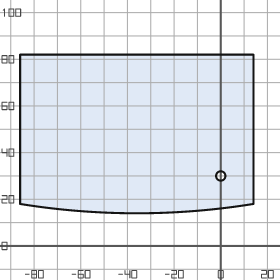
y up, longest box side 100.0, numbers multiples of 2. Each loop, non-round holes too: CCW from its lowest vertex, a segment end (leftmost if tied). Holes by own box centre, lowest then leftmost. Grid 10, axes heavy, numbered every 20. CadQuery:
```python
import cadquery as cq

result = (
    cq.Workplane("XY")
    .moveTo(-86.0, 18.0)
    .threePointArc((-36.0, 14.0), (14.0, 18.0))
    .lineTo(14.0, 82.0)
    .lineTo(-86.0, 82.0)
    .close()
    .moveTo(0.0, 30.0)
    .circle(2.0)
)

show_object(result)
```